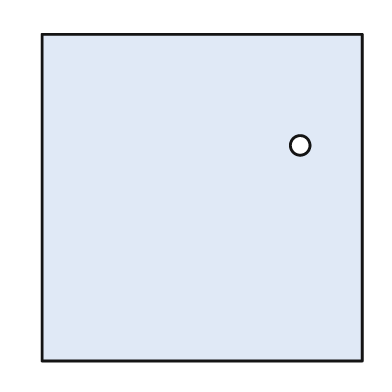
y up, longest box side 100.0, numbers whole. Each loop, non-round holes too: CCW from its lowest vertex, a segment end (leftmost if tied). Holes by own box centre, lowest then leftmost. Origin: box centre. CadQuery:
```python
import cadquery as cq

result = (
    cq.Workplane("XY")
    .moveTo(-49.0, -50.0)
    .lineTo(49.0, -50.0)
    .lineTo(49.0, 50.0)
    .lineTo(-49.0, 50.0)
    .close()
    .moveTo(30.0, 16.0)
    .circle(3.0)
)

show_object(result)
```